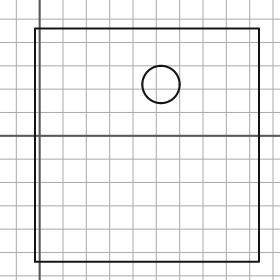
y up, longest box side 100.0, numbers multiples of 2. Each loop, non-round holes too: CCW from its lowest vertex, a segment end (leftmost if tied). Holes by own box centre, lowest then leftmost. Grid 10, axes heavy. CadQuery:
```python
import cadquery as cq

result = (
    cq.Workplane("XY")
    .moveTo(-2.0, -54.0)
    .lineTo(94.0, -54.0)
    .lineTo(94.0, 46.0)
    .lineTo(-2.0, 46.0)
    .close()
    .moveTo(52.0, 22.0)
    .circle(8.0)
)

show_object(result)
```